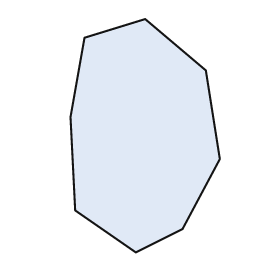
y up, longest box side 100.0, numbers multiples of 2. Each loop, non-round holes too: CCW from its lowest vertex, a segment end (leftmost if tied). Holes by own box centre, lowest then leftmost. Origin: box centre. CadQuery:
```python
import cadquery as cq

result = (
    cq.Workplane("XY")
    .moveTo(-4.0, -50.0)
    .lineTo(16.0, -40.0)
    .lineTo(32.0, -10.0)
    .lineTo(26.0, 28.0)
    .lineTo(0.0, 50.0)
    .lineTo(-26.0, 42.0)
    .lineTo(-32.0, 8.0)
    .lineTo(-30.0, -32.0)
    .close()
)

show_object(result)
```